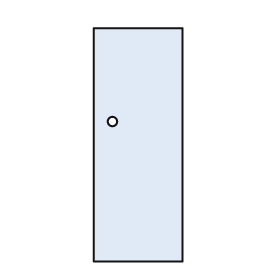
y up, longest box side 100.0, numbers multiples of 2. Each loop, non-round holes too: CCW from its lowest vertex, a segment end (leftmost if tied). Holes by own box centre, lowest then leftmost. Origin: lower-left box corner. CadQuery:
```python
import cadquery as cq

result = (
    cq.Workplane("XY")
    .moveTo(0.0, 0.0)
    .lineTo(38.0, 0.0)
    .lineTo(38.0, 100.0)
    .lineTo(0.0, 100.0)
    .close()
    .moveTo(8.0, 60.0)
    .circle(2.0)
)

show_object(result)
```